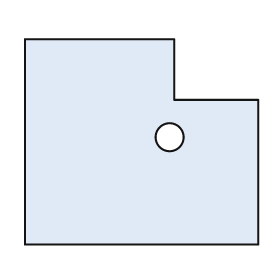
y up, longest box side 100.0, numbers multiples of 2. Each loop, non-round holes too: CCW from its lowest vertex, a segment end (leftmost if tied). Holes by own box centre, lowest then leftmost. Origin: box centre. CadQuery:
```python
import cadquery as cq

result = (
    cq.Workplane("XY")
    .moveTo(-50.0, -44.0)
    .lineTo(50.0, -44.0)
    .lineTo(50.0, 18.0)
    .lineTo(14.0, 18.0)
    .lineTo(14.0, 44.0)
    .lineTo(-50.0, 44.0)
    .close()
    .moveTo(12.0, 2.0)
    .circle(6.0)
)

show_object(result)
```